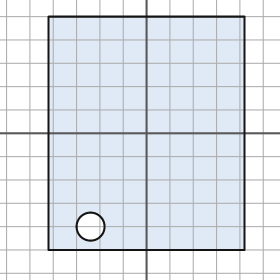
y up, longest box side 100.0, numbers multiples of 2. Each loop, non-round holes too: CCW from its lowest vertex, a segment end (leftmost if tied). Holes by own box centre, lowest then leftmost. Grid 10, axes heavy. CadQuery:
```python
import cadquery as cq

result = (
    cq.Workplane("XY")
    .moveTo(-42.0, -50.0)
    .lineTo(42.0, -50.0)
    .lineTo(42.0, 50.0)
    .lineTo(-42.0, 50.0)
    .close()
    .moveTo(-24.0, -40.0)
    .circle(6.0)
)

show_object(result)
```